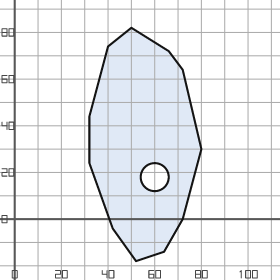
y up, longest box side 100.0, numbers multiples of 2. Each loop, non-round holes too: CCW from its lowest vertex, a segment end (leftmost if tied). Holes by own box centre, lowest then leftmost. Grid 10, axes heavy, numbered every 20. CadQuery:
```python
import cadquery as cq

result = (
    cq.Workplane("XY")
    .moveTo(52.0, -18.0)
    .lineTo(64.0, -14.0)
    .lineTo(72.0, 0.0)
    .lineTo(80.0, 30.0)
    .lineTo(72.0, 64.0)
    .lineTo(66.0, 72.0)
    .lineTo(50.0, 82.0)
    .lineTo(40.0, 74.0)
    .lineTo(32.0, 44.0)
    .lineTo(32.0, 24.0)
    .lineTo(42.0, -4.0)
    .close()
    .moveTo(60.0, 18.0)
    .circle(6.0)
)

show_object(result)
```